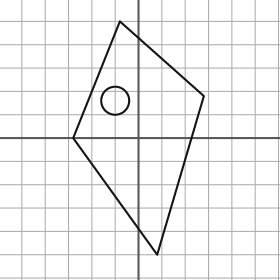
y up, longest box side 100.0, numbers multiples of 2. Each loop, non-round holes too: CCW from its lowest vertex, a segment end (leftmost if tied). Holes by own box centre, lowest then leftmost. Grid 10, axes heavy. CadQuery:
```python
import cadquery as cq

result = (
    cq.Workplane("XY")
    .moveTo(8.0, -50.0)
    .lineTo(28.0, 18.0)
    .lineTo(-8.0, 50.0)
    .lineTo(-28.0, 0.0)
    .close()
    .moveTo(-10.0, 16.0)
    .circle(6.0)
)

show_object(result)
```